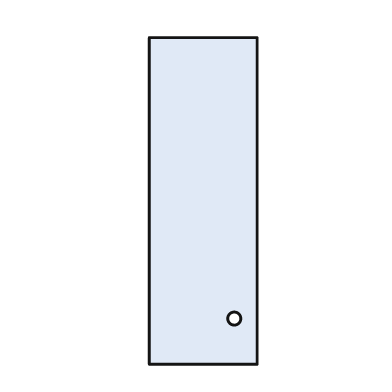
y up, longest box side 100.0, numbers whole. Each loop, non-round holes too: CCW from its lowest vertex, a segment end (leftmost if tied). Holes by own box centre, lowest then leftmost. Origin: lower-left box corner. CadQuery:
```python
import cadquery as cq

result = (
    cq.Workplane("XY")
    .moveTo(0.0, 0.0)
    .lineTo(33.0, 0.0)
    .lineTo(33.0, 100.0)
    .lineTo(0.0, 100.0)
    .close()
    .moveTo(26.0, 14.0)
    .circle(2.0)
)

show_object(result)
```